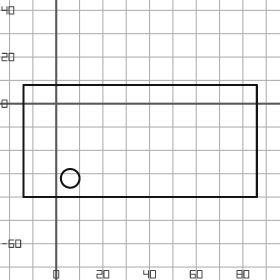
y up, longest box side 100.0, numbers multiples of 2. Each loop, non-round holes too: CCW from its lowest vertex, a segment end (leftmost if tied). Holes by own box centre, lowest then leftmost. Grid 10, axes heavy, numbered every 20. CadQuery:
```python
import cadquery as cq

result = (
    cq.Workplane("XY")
    .moveTo(-14.0, -40.0)
    .lineTo(86.0, -40.0)
    .lineTo(86.0, 8.0)
    .lineTo(-14.0, 8.0)
    .close()
    .moveTo(6.0, -32.0)
    .circle(4.0)
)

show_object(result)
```